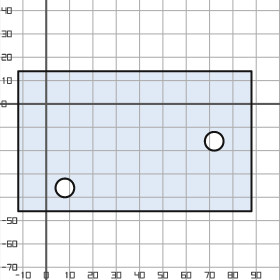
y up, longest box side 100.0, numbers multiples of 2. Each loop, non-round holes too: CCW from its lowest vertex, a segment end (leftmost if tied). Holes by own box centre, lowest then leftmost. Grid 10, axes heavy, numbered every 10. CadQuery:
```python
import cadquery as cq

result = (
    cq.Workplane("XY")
    .moveTo(-12.0, -46.0)
    .lineTo(88.0, -46.0)
    .lineTo(88.0, 14.0)
    .lineTo(-12.0, 14.0)
    .close()
    .moveTo(8.0, -36.0)
    .circle(4.0)
    .moveTo(72.0, -16.0)
    .circle(4.0)
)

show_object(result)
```